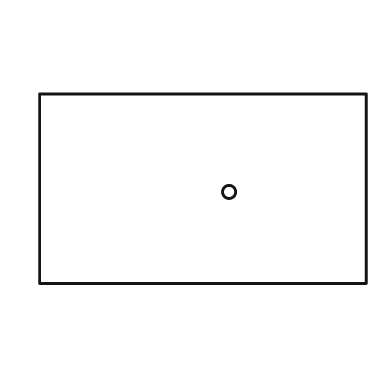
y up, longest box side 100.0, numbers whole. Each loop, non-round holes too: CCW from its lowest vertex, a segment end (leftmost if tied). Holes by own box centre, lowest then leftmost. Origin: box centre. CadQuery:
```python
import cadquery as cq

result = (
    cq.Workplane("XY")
    .moveTo(-50.0, -29.0)
    .lineTo(50.0, -29.0)
    .lineTo(50.0, 29.0)
    .lineTo(-50.0, 29.0)
    .close()
    .moveTo(8.0, -1.0)
    .circle(2.0)
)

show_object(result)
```